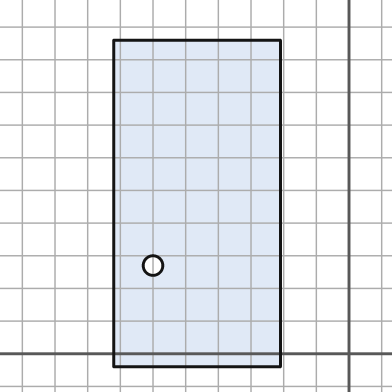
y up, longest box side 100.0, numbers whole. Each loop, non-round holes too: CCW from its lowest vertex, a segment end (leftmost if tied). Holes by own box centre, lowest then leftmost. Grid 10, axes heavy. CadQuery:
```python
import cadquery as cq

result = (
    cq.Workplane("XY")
    .moveTo(-72.0, -4.0)
    .lineTo(-21.0, -4.0)
    .lineTo(-21.0, 96.0)
    .lineTo(-72.0, 96.0)
    .close()
    .moveTo(-60.0, 27.0)
    .circle(3.0)
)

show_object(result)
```